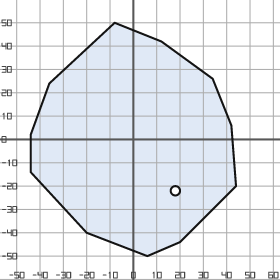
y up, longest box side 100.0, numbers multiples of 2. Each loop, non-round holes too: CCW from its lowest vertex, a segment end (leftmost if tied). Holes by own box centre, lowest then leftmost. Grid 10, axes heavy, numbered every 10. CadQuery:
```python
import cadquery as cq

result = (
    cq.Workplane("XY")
    .moveTo(6.0, -50.0)
    .lineTo(20.0, -44.0)
    .lineTo(44.0, -20.0)
    .lineTo(42.0, 6.0)
    .lineTo(34.0, 26.0)
    .lineTo(12.0, 42.0)
    .lineTo(-8.0, 50.0)
    .lineTo(-36.0, 24.0)
    .lineTo(-44.0, 2.0)
    .lineTo(-44.0, -14.0)
    .lineTo(-20.0, -40.0)
    .close()
    .moveTo(18.0, -22.0)
    .circle(2.0)
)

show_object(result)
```